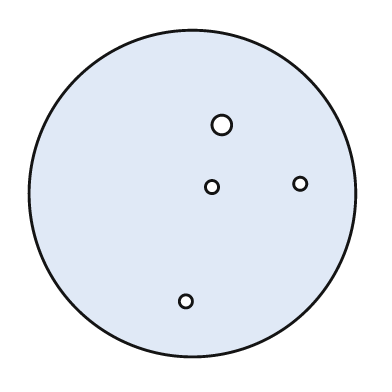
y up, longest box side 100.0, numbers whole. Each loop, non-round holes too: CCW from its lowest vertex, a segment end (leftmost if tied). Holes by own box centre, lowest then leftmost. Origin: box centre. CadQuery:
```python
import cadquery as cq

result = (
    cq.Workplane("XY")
    .moveTo(0.0, 0.0)
    .circle(50.0)
    .moveTo(-2.0, -33.0)
    .circle(2.0)
    .moveTo(6.0, 2.0)
    .circle(2.0)
    .moveTo(33.0, 3.0)
    .circle(2.0)
    .moveTo(9.0, 21.0)
    .circle(3.0)
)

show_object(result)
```